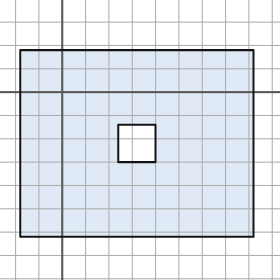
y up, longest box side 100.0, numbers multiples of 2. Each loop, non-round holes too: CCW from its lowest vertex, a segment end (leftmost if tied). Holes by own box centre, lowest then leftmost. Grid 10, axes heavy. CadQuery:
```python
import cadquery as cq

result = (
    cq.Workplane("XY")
    .moveTo(-18.0, -62.0)
    .lineTo(82.0, -62.0)
    .lineTo(82.0, 18.0)
    .lineTo(-18.0, 18.0)
    .close()
    .moveTo(24.0, -30.0)
    .lineTo(40.0, -30.0)
    .lineTo(40.0, -14.0)
    .lineTo(24.0, -14.0)
    .close()
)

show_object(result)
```